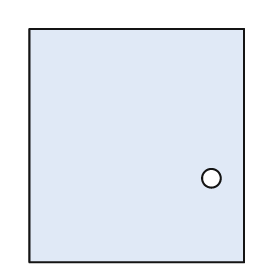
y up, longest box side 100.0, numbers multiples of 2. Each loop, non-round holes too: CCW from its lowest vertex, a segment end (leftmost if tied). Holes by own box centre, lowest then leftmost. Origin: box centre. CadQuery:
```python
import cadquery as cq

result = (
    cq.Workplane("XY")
    .moveTo(-46.0, -50.0)
    .lineTo(46.0, -50.0)
    .lineTo(46.0, 50.0)
    .lineTo(-46.0, 50.0)
    .close()
    .moveTo(32.0, -14.0)
    .circle(4.0)
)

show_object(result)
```